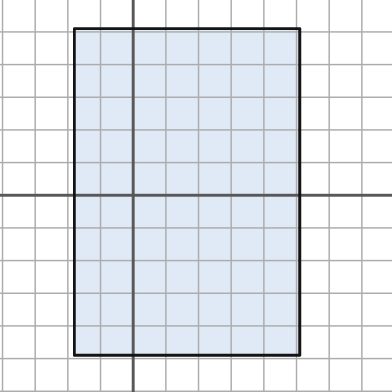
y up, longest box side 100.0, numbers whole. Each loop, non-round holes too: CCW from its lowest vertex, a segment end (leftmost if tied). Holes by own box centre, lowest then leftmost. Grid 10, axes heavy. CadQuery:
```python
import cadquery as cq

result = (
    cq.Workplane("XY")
    .moveTo(-18.0, -49.0)
    .lineTo(51.0, -49.0)
    .lineTo(51.0, 51.0)
    .lineTo(-18.0, 51.0)
    .close()
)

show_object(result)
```